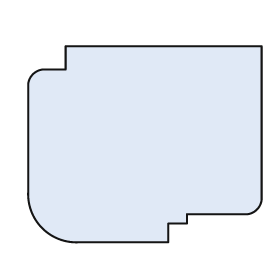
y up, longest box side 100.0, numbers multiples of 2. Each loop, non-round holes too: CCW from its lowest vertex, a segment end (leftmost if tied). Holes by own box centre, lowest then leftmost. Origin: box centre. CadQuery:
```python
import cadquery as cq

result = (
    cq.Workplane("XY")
    .moveTo(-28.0, -42.0)
    .lineTo(10.0, -42.0)
    .lineTo(10.0, -34.0)
    .lineTo(18.0, -34.0)
    .lineTo(18.0, -30.0)
    .lineTo(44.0, -30.0)
    .threePointArc((48.0, -28.0), (50.0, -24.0))
    .lineTo(50.0, 42.0)
    .lineTo(-34.0, 42.0)
    .lineTo(-34.0, 32.0)
    .lineTo(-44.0, 32.0)
    .threePointArc((-48.0, 30.0), (-50.0, 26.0))
    .lineTo(-50.0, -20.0)
    .threePointArc((-44.0, -36.0), (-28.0, -42.0))
    .close()
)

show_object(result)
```